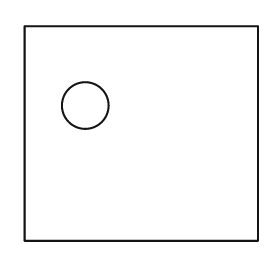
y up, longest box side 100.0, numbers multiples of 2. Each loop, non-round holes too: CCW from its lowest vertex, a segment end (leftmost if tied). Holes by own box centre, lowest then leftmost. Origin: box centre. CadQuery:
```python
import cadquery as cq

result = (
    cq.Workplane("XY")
    .moveTo(-50.0, -46.0)
    .lineTo(50.0, -46.0)
    .lineTo(50.0, 46.0)
    .lineTo(-50.0, 46.0)
    .close()
    .moveTo(-24.0, 12.0)
    .circle(10.0)
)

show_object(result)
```